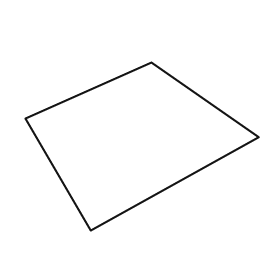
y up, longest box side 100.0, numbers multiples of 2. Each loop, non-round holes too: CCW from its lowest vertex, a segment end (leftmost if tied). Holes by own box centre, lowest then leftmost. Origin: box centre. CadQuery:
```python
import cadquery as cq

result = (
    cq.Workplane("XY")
    .moveTo(-22.0, -36.0)
    .lineTo(50.0, 4.0)
    .lineTo(4.0, 36.0)
    .lineTo(-50.0, 12.0)
    .close()
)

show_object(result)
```